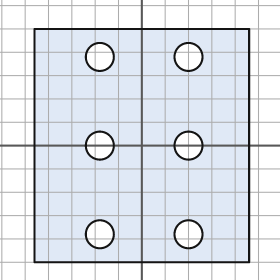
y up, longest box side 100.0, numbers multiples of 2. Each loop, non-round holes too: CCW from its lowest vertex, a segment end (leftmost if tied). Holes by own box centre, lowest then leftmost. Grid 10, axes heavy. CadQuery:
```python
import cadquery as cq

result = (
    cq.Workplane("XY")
    .moveTo(-46.0, -50.0)
    .lineTo(46.0, -50.0)
    .lineTo(46.0, 50.0)
    .lineTo(-46.0, 50.0)
    .close()
    .moveTo(-18.0, -38.0)
    .circle(6.0)
    .moveTo(20.0, -38.0)
    .circle(6.0)
    .moveTo(-18.0, 0.0)
    .circle(6.0)
    .moveTo(20.0, 0.0)
    .circle(6.0)
    .moveTo(-18.0, 38.0)
    .circle(6.0)
    .moveTo(20.0, 38.0)
    .circle(6.0)
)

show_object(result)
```